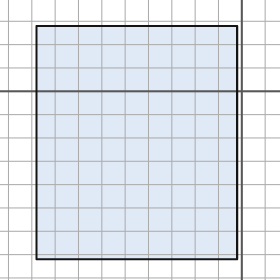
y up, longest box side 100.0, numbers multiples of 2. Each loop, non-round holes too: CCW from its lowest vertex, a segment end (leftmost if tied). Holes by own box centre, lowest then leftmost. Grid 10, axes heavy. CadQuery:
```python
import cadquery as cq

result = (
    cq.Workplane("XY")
    .moveTo(-88.0, -72.0)
    .lineTo(-2.0, -72.0)
    .lineTo(-2.0, 28.0)
    .lineTo(-88.0, 28.0)
    .close()
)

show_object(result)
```